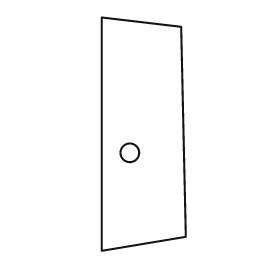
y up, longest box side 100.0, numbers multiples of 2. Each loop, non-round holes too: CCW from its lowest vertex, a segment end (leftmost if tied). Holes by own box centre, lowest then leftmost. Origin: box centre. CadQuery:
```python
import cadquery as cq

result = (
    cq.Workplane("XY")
    .moveTo(-18.0, -50.0)
    .lineTo(18.0, -44.0)
    .lineTo(16.0, 46.0)
    .lineTo(-18.0, 50.0)
    .close()
    .moveTo(-6.0, -8.0)
    .circle(4.0)
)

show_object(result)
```